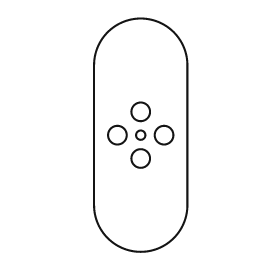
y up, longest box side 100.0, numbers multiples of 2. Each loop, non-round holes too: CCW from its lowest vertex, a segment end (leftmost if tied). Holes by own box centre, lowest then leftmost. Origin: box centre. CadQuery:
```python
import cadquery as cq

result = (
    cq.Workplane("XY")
    .moveTo(-20.0, -30.0)
    .threePointArc((0.0, -50.0), (20.0, -30.0))
    .lineTo(20.0, 30.0)
    .threePointArc((0.0, 50.0), (-20.0, 30.0))
    .close()
    .moveTo(0.0, -10.0)
    .circle(4.0)
    .moveTo(-10.0, 0.0)
    .circle(4.0)
    .moveTo(0.0, 0.0)
    .circle(2.0)
    .moveTo(10.0, 0.0)
    .circle(4.0)
    .moveTo(0.0, 10.0)
    .circle(4.0)
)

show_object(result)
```